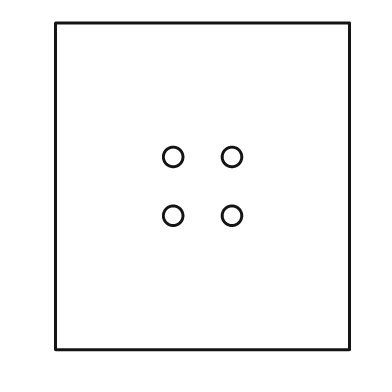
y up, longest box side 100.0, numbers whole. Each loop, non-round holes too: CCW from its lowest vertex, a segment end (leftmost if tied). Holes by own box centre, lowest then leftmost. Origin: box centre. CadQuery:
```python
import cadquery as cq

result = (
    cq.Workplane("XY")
    .moveTo(-45.0, -50.0)
    .lineTo(45.0, -50.0)
    .lineTo(45.0, 50.0)
    .lineTo(-45.0, 50.0)
    .close()
    .moveTo(-9.0, -9.0)
    .circle(3.0)
    .moveTo(9.0, -9.0)
    .circle(3.0)
    .moveTo(-9.0, 9.0)
    .circle(3.0)
    .moveTo(9.0, 9.0)
    .circle(3.0)
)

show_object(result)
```